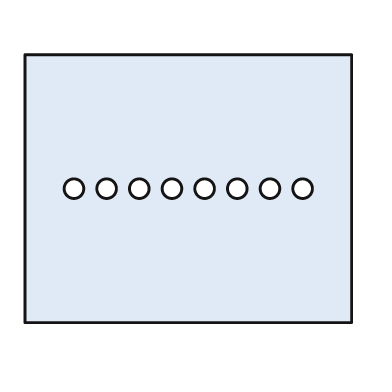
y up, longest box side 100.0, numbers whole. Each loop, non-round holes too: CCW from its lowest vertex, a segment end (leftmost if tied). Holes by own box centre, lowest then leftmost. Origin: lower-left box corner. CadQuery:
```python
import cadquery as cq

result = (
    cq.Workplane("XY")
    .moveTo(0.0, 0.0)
    .lineTo(100.0, 0.0)
    .lineTo(100.0, 82.0)
    .lineTo(0.0, 82.0)
    .close()
    .moveTo(15.0, 41.0)
    .circle(3.0)
    .moveTo(25.0, 41.0)
    .circle(3.0)
    .moveTo(35.0, 41.0)
    .circle(3.0)
    .moveTo(45.0, 41.0)
    .circle(3.0)
    .moveTo(55.0, 41.0)
    .circle(3.0)
    .moveTo(65.0, 41.0)
    .circle(3.0)
    .moveTo(75.0, 41.0)
    .circle(3.0)
    .moveTo(85.0, 41.0)
    .circle(3.0)
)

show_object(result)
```